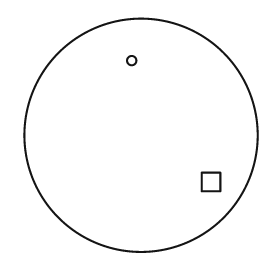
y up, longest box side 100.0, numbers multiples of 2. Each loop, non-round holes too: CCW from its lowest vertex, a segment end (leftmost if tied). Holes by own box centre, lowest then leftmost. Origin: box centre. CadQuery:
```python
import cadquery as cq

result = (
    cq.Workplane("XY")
    .moveTo(0.0, 0.0)
    .circle(50.0)
    .moveTo(26.0, -24.0)
    .lineTo(34.0, -24.0)
    .lineTo(34.0, -16.0)
    .lineTo(26.0, -16.0)
    .close()
    .moveTo(-4.0, 32.0)
    .circle(2.0)
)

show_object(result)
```